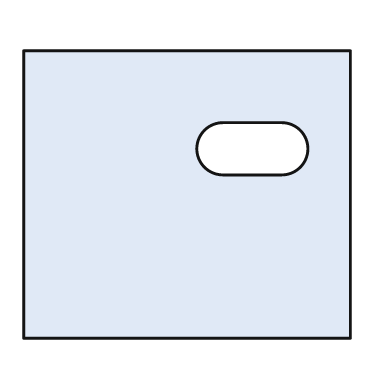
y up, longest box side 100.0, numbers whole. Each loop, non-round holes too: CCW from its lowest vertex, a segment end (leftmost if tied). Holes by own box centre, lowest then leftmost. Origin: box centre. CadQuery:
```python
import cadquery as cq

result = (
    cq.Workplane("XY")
    .moveTo(-50.0, -44.0)
    .lineTo(50.0, -44.0)
    .lineTo(50.0, 44.0)
    .lineTo(-50.0, 44.0)
    .close()
    .moveTo(11.0, 6.0)
    .lineTo(29.0, 6.0)
    .threePointArc((37.0, 14.0), (29.0, 22.0))
    .lineTo(11.0, 22.0)
    .threePointArc((3.0, 14.0), (11.0, 6.0))
    .close()
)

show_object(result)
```